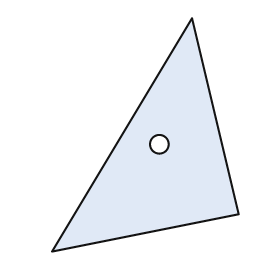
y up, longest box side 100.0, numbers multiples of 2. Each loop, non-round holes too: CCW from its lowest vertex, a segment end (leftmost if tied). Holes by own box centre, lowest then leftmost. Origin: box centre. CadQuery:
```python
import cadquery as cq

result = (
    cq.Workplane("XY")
    .moveTo(-40.0, -50.0)
    .lineTo(40.0, -34.0)
    .lineTo(20.0, 50.0)
    .close()
    .moveTo(6.0, -4.0)
    .circle(4.0)
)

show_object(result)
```